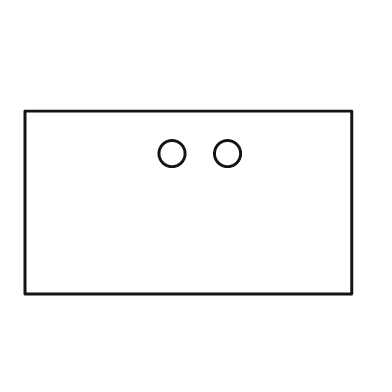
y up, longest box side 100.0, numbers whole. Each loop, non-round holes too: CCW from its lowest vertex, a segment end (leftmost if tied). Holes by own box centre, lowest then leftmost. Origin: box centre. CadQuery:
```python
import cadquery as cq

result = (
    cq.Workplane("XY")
    .moveTo(-50.0, -28.0)
    .lineTo(50.0, -28.0)
    .lineTo(50.0, 28.0)
    .lineTo(-50.0, 28.0)
    .close()
    .moveTo(-5.0, 15.0)
    .circle(4.0)
    .moveTo(12.0, 15.0)
    .circle(4.0)
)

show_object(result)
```